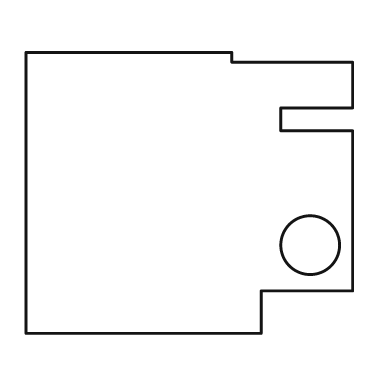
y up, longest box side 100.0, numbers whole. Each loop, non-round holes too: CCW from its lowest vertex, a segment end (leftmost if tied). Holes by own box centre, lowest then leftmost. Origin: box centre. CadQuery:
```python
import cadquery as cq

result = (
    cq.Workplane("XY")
    .moveTo(-50.0, -43.0)
    .lineTo(22.0, -43.0)
    .lineTo(22.0, -30.0)
    .lineTo(50.0, -30.0)
    .lineTo(50.0, 19.0)
    .lineTo(28.0, 19.0)
    .lineTo(28.0, 26.0)
    .lineTo(50.0, 26.0)
    .lineTo(50.0, 40.0)
    .lineTo(13.0, 40.0)
    .lineTo(13.0, 43.0)
    .lineTo(-50.0, 43.0)
    .close()
    .moveTo(37.0, -16.0)
    .circle(9.0)
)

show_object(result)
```